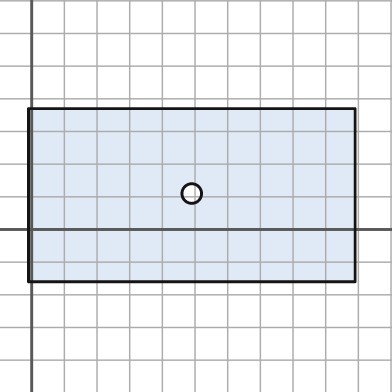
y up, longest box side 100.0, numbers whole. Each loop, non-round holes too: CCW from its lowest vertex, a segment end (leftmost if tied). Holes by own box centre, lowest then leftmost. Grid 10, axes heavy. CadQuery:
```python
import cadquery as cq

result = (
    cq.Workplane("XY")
    .moveTo(-1.0, -16.0)
    .lineTo(99.0, -16.0)
    .lineTo(99.0, 37.0)
    .lineTo(-1.0, 37.0)
    .close()
    .moveTo(49.0, 11.0)
    .circle(3.0)
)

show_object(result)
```